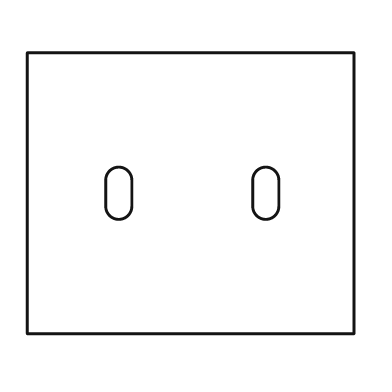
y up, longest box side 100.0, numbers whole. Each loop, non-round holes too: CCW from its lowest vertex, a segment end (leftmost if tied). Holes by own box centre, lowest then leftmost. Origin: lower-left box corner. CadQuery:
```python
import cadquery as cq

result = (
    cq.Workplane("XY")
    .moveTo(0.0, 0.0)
    .lineTo(100.0, 0.0)
    .lineTo(100.0, 86.0)
    .lineTo(0.0, 86.0)
    .close()
    .moveTo(24.0, 39.0)
    .threePointArc((28.0, 35.0), (32.0, 39.0))
    .lineTo(32.0, 47.0)
    .threePointArc((28.0, 51.0), (24.0, 47.0))
    .close()
    .moveTo(69.0, 39.0)
    .threePointArc((73.0, 35.0), (77.0, 39.0))
    .lineTo(77.0, 47.0)
    .threePointArc((73.0, 51.0), (69.0, 47.0))
    .close()
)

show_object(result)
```